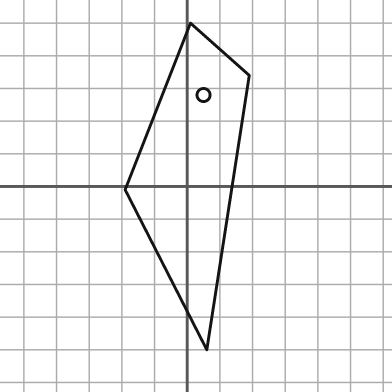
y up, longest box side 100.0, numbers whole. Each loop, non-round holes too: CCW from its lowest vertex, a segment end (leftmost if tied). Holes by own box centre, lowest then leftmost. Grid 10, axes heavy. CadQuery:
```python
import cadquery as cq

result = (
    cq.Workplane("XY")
    .moveTo(6.0, -50.0)
    .lineTo(19.0, 34.0)
    .lineTo(1.0, 50.0)
    .lineTo(-19.0, -1.0)
    .close()
    .moveTo(5.0, 28.0)
    .circle(2.0)
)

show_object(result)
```